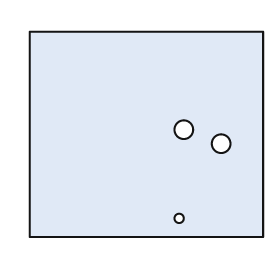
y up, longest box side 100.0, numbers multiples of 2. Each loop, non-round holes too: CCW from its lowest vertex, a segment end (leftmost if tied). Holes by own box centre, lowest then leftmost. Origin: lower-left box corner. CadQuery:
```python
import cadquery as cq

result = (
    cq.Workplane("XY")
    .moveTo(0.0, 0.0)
    .lineTo(100.0, 0.0)
    .lineTo(100.0, 88.0)
    .lineTo(0.0, 88.0)
    .close()
    .moveTo(64.0, 8.0)
    .circle(2.0)
    .moveTo(82.0, 40.0)
    .circle(4.0)
    .moveTo(66.0, 46.0)
    .circle(4.0)
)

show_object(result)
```